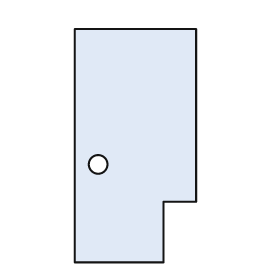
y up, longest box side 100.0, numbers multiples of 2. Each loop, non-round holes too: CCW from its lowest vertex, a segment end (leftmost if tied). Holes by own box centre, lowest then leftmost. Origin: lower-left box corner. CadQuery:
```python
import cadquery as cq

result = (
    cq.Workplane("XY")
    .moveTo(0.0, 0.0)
    .lineTo(38.0, 0.0)
    .lineTo(38.0, 26.0)
    .lineTo(52.0, 26.0)
    .lineTo(52.0, 100.0)
    .lineTo(0.0, 100.0)
    .close()
    .moveTo(10.0, 42.0)
    .circle(4.0)
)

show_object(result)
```